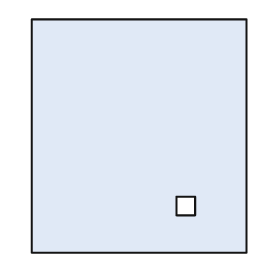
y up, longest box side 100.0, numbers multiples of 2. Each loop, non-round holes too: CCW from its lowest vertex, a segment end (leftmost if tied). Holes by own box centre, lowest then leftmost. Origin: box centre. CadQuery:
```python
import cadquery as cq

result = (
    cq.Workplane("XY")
    .moveTo(-46.0, -50.0)
    .lineTo(46.0, -50.0)
    .lineTo(46.0, 50.0)
    .lineTo(-46.0, 50.0)
    .close()
    .moveTo(16.0, -34.0)
    .lineTo(24.0, -34.0)
    .lineTo(24.0, -26.0)
    .lineTo(16.0, -26.0)
    .close()
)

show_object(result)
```